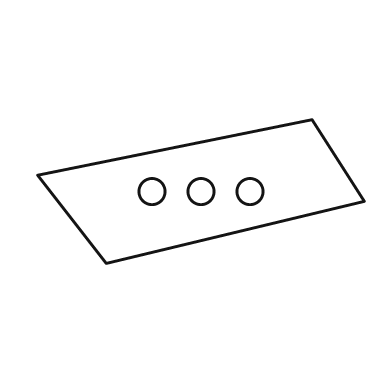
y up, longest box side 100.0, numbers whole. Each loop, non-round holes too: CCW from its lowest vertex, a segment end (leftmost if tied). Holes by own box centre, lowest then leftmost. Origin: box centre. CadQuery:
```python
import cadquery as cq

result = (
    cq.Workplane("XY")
    .moveTo(-29.0, -22.0)
    .lineTo(50.0, -3.0)
    .lineTo(34.0, 22.0)
    .lineTo(-50.0, 5.0)
    .close()
    .moveTo(-15.0, 0.0)
    .circle(4.0)
    .moveTo(0.0, 0.0)
    .circle(4.0)
    .moveTo(15.0, 0.0)
    .circle(4.0)
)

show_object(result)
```